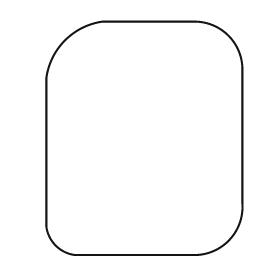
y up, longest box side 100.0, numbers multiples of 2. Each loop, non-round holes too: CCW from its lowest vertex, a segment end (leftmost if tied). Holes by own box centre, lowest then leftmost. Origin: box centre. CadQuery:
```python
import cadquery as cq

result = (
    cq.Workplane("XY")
    .moveTo(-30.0, -50.0)
    .lineTo(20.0, -50.0)
    .threePointArc((36.0, -44.0), (42.0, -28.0))
    .lineTo(42.0, 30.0)
    .threePointArc((36.0, 44.0), (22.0, 50.0))
    .lineTo(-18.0, 50.0)
    .threePointArc((-34.0, 42.0), (-42.0, 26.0))
    .lineTo(-42.0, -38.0)
    .threePointArc((-38.0, -46.0), (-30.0, -50.0))
    .close()
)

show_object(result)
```